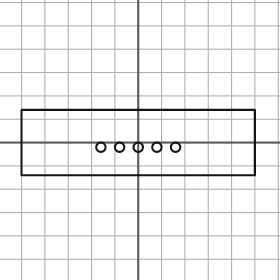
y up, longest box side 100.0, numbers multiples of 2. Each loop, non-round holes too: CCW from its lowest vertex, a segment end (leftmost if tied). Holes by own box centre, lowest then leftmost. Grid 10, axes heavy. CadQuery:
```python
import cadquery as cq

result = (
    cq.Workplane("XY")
    .moveTo(-50.0, -14.0)
    .lineTo(50.0, -14.0)
    .lineTo(50.0, 14.0)
    .lineTo(-50.0, 14.0)
    .close()
    .moveTo(-16.0, -2.0)
    .circle(2.0)
    .moveTo(-8.0, -2.0)
    .circle(2.0)
    .moveTo(0.0, -2.0)
    .circle(2.0)
    .moveTo(8.0, -2.0)
    .circle(2.0)
    .moveTo(16.0, -2.0)
    .circle(2.0)
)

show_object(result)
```